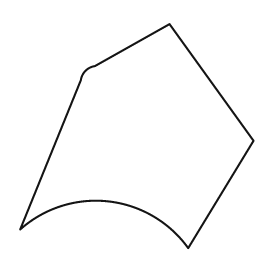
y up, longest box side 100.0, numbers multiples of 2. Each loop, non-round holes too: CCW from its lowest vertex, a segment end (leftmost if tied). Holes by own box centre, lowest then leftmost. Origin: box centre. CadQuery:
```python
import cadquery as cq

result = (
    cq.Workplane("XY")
    .moveTo(22.0, -48.0)
    .lineTo(50.0, -2.0)
    .lineTo(14.0, 48.0)
    .lineTo(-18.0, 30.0)
    .threePointArc((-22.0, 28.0), (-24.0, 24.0))
    .lineTo(-50.0, -40.0)
    .threePointArc((-12.0, -28.0), (22.0, -48.0))
    .close()
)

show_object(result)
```